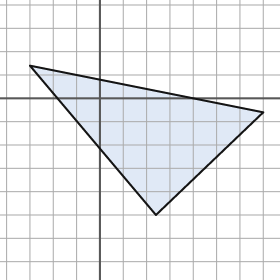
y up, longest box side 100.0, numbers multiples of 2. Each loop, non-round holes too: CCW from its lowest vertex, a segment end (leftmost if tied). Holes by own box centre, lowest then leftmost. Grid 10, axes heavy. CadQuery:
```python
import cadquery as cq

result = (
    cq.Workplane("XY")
    .moveTo(24.0, -50.0)
    .lineTo(70.0, -6.0)
    .lineTo(-30.0, 14.0)
    .close()
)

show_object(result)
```